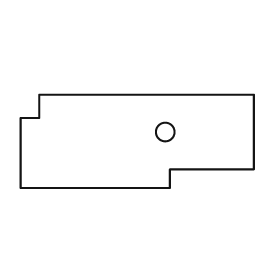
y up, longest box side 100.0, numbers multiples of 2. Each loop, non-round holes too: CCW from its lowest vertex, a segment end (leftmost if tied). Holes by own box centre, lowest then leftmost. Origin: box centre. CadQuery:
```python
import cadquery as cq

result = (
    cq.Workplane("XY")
    .moveTo(-50.0, -20.0)
    .lineTo(14.0, -20.0)
    .lineTo(14.0, -12.0)
    .lineTo(50.0, -12.0)
    .lineTo(50.0, 20.0)
    .lineTo(-42.0, 20.0)
    .lineTo(-42.0, 10.0)
    .lineTo(-50.0, 10.0)
    .close()
    .moveTo(12.0, 4.0)
    .circle(4.0)
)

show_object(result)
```